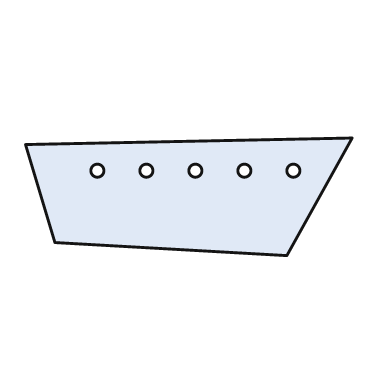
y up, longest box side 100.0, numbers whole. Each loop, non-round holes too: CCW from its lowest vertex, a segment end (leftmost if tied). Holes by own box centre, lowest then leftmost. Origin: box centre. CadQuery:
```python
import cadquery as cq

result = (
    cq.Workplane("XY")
    .moveTo(30.0, -18.0)
    .lineTo(50.0, 18.0)
    .lineTo(-50.0, 16.0)
    .lineTo(-41.0, -14.0)
    .close()
    .moveTo(-28.0, 8.0)
    .circle(2.0)
    .moveTo(-13.0, 8.0)
    .circle(2.0)
    .moveTo(2.0, 8.0)
    .circle(2.0)
    .moveTo(17.0, 8.0)
    .circle(2.0)
    .moveTo(32.0, 8.0)
    .circle(2.0)
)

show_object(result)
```